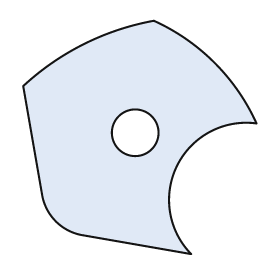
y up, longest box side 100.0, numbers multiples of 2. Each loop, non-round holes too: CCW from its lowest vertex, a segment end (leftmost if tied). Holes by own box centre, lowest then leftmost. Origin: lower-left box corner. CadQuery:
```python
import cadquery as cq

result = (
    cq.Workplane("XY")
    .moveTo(72.0, 0.0)
    .threePointArc((66.0, 38.0), (100.0, 56.0))
    .threePointArc((82.0, 82.0), (56.0, 100.0))
    .threePointArc((26.0, 90.0), (0.0, 72.0))
    .lineTo(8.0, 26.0)
    .threePointArc((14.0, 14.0), (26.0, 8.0))
    .close()
    .moveTo(48.0, 52.0)
    .circle(10.0)
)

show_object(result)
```